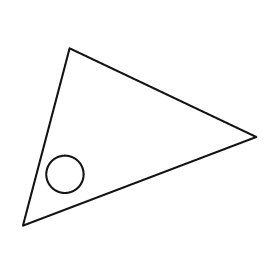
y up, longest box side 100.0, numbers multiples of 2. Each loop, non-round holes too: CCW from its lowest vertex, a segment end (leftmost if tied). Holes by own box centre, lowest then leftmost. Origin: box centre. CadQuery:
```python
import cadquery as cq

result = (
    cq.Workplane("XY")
    .moveTo(-50.0, -38.0)
    .lineTo(50.0, 0.0)
    .lineTo(-30.0, 38.0)
    .close()
    .moveTo(-32.0, -16.0)
    .circle(8.0)
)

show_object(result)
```